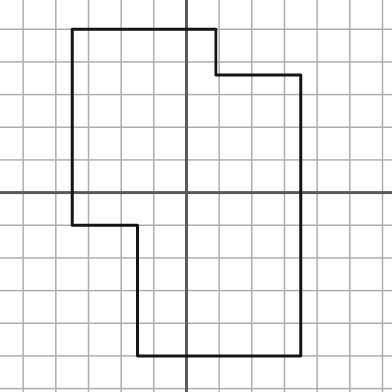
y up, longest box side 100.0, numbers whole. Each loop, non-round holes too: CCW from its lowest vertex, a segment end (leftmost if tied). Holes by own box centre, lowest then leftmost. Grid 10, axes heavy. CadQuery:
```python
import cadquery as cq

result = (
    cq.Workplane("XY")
    .moveTo(-15.0, -50.0)
    .lineTo(35.0, -50.0)
    .lineTo(35.0, 36.0)
    .lineTo(9.0, 36.0)
    .lineTo(9.0, 50.0)
    .lineTo(-35.0, 50.0)
    .lineTo(-35.0, -10.0)
    .lineTo(-15.0, -10.0)
    .close()
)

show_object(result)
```